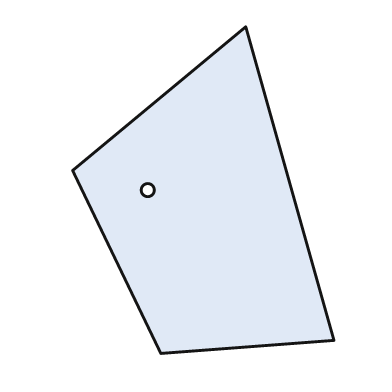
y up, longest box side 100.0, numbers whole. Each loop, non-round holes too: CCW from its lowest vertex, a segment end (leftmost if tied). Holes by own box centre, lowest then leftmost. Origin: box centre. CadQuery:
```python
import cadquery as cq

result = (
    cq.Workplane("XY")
    .moveTo(-13.0, -50.0)
    .lineTo(40.0, -46.0)
    .lineTo(13.0, 50.0)
    .lineTo(-40.0, 6.0)
    .close()
    .moveTo(-17.0, 0.0)
    .circle(2.0)
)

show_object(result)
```